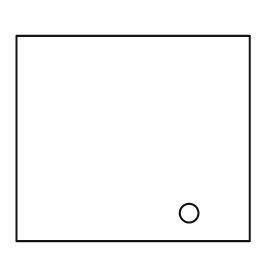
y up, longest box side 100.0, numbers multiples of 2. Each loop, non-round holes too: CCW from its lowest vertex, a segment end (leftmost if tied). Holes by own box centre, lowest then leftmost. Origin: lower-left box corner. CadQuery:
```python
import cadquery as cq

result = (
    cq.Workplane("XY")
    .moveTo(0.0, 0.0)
    .lineTo(100.0, 0.0)
    .lineTo(100.0, 88.0)
    .lineTo(0.0, 88.0)
    .close()
    .moveTo(74.0, 12.0)
    .circle(4.0)
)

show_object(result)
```